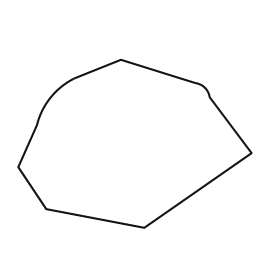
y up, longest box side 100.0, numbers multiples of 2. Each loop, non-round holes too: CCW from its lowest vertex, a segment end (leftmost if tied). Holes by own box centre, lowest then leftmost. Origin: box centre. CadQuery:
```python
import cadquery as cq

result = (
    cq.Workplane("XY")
    .moveTo(4.0, -36.0)
    .lineTo(50.0, -4.0)
    .lineTo(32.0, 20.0)
    .threePointArc((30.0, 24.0), (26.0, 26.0))
    .lineTo(-6.0, 36.0)
    .lineTo(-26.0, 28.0)
    .threePointArc((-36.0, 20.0), (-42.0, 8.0))
    .lineTo(-50.0, -10.0)
    .lineTo(-38.0, -28.0)
    .close()
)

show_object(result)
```